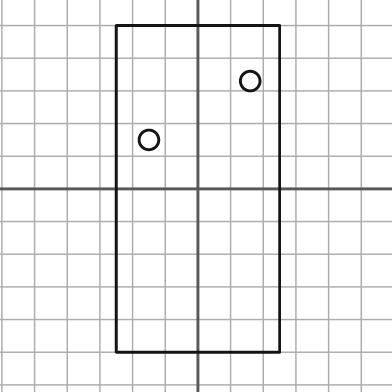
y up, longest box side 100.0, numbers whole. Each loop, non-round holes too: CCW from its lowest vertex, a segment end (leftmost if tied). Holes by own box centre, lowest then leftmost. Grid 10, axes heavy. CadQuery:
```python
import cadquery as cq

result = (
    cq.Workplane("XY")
    .moveTo(-25.0, -50.0)
    .lineTo(25.0, -50.0)
    .lineTo(25.0, 50.0)
    .lineTo(-25.0, 50.0)
    .close()
    .moveTo(-15.0, 15.0)
    .circle(3.0)
    .moveTo(16.0, 33.0)
    .circle(3.0)
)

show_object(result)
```